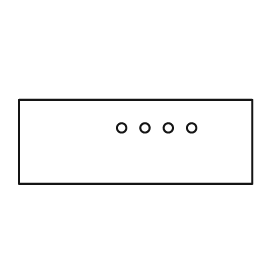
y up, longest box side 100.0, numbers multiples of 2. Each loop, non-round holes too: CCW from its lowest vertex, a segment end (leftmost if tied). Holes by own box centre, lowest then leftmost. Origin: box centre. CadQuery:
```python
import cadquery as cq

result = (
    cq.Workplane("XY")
    .moveTo(-50.0, -18.0)
    .lineTo(50.0, -18.0)
    .lineTo(50.0, 18.0)
    .lineTo(-50.0, 18.0)
    .close()
    .moveTo(-6.0, 6.0)
    .circle(2.0)
    .moveTo(4.0, 6.0)
    .circle(2.0)
    .moveTo(14.0, 6.0)
    .circle(2.0)
    .moveTo(24.0, 6.0)
    .circle(2.0)
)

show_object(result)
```